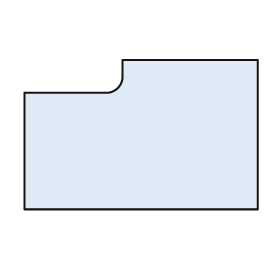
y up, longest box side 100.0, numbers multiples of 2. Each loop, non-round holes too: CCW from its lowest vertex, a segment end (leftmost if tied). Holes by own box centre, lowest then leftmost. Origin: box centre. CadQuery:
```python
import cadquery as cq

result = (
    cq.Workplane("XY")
    .moveTo(-50.0, -32.0)
    .lineTo(50.0, -32.0)
    .lineTo(50.0, 32.0)
    .lineTo(-8.0, 32.0)
    .lineTo(-8.0, 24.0)
    .threePointArc((-10.0, 20.0), (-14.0, 18.0))
    .lineTo(-50.0, 18.0)
    .close()
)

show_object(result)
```